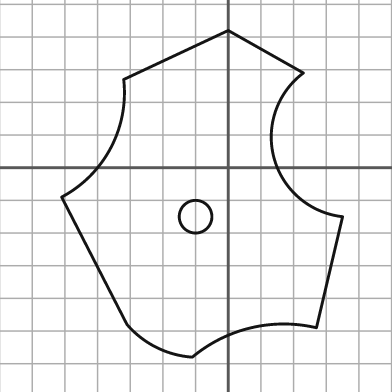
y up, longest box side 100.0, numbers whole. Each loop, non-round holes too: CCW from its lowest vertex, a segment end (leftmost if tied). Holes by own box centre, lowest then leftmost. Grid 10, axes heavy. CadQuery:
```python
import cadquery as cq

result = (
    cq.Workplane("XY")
    .moveTo(-11.0, -58.0)
    .threePointArc((7.0, -49.0), (27.0, -49.0))
    .lineTo(35.0, -15.0)
    .threePointArc((14.0, 3.0), (23.0, 29.0))
    .lineTo(0.0, 42.0)
    .lineTo(-32.0, 27.0)
    .threePointArc((-36.0, 6.0), (-51.0, -9.0))
    .lineTo(-31.0, -48.0)
    .threePointArc((-22.0, -55.0), (-11.0, -58.0))
    .close()
    .moveTo(-10.0, -15.0)
    .circle(5.0)
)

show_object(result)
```